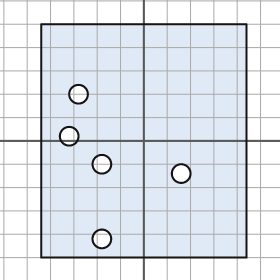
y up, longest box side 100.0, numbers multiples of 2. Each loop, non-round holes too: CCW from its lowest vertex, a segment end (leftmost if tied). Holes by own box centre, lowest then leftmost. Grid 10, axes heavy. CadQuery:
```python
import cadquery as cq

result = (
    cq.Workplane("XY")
    .moveTo(-44.0, -50.0)
    .lineTo(44.0, -50.0)
    .lineTo(44.0, 50.0)
    .lineTo(-44.0, 50.0)
    .close()
    .moveTo(-18.0, -42.0)
    .circle(4.0)
    .moveTo(16.0, -14.0)
    .circle(4.0)
    .moveTo(-18.0, -10.0)
    .circle(4.0)
    .moveTo(-32.0, 2.0)
    .circle(4.0)
    .moveTo(-28.0, 20.0)
    .circle(4.0)
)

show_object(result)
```